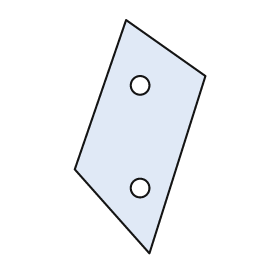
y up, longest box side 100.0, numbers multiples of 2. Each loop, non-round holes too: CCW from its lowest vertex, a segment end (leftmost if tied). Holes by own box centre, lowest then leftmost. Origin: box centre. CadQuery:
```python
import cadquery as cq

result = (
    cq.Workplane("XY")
    .moveTo(4.0, -50.0)
    .lineTo(28.0, 26.0)
    .lineTo(-6.0, 50.0)
    .lineTo(-28.0, -14.0)
    .close()
    .moveTo(0.0, -22.0)
    .circle(4.0)
    .moveTo(0.0, 22.0)
    .circle(4.0)
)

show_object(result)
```